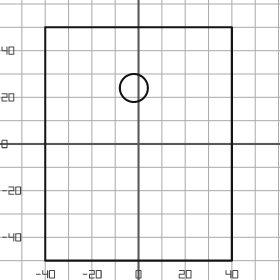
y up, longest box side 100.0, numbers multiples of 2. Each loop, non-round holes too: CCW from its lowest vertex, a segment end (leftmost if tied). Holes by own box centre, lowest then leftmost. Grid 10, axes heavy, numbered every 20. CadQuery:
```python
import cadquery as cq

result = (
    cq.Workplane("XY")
    .moveTo(-40.0, -50.0)
    .lineTo(40.0, -50.0)
    .lineTo(40.0, 50.0)
    .lineTo(-40.0, 50.0)
    .close()
    .moveTo(-2.0, 24.0)
    .circle(6.0)
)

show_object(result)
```